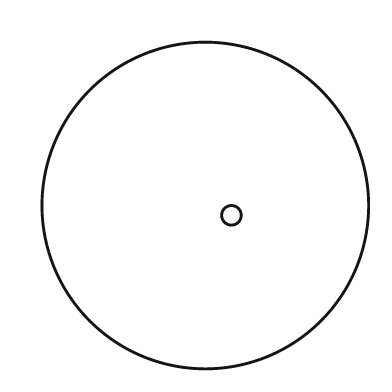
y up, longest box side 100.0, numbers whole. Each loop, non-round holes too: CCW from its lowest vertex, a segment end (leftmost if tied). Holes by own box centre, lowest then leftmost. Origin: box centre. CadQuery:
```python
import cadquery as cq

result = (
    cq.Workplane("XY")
    .moveTo(0.0, 0.0)
    .circle(50.0)
    .moveTo(8.0, -3.0)
    .circle(3.0)
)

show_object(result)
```